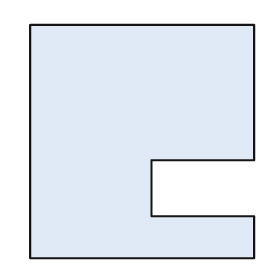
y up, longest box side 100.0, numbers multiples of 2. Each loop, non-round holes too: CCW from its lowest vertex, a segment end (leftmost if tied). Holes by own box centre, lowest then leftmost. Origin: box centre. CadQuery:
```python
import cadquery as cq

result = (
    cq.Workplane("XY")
    .moveTo(-48.0, -50.0)
    .lineTo(48.0, -50.0)
    .lineTo(48.0, -32.0)
    .lineTo(4.0, -32.0)
    .lineTo(4.0, -8.0)
    .lineTo(48.0, -8.0)
    .lineTo(48.0, 50.0)
    .lineTo(-48.0, 50.0)
    .close()
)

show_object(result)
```